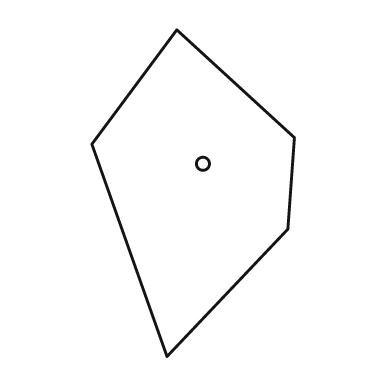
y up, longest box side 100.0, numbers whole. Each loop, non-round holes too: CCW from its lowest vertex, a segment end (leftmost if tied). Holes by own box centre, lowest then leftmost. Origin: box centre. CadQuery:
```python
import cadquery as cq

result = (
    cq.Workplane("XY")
    .moveTo(-8.0, -50.0)
    .lineTo(29.0, -11.0)
    .lineTo(31.0, 17.0)
    .lineTo(-5.0, 50.0)
    .lineTo(-31.0, 15.0)
    .close()
    .moveTo(3.0, 9.0)
    .circle(2.0)
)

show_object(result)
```